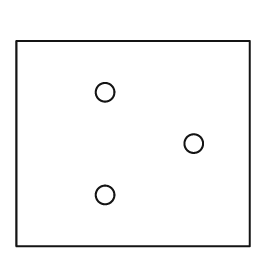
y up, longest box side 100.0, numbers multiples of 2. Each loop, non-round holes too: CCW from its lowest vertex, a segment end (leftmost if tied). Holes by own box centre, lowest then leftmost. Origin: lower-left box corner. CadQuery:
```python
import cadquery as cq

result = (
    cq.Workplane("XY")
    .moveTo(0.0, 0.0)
    .lineTo(100.0, 0.0)
    .lineTo(100.0, 88.0)
    .lineTo(0.0, 88.0)
    .close()
    .moveTo(38.0, 22.0)
    .circle(4.0)
    .moveTo(76.0, 44.0)
    .circle(4.0)
    .moveTo(38.0, 66.0)
    .circle(4.0)
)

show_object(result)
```